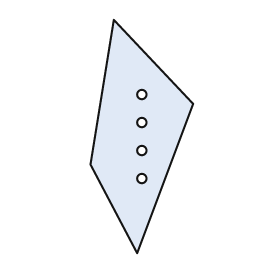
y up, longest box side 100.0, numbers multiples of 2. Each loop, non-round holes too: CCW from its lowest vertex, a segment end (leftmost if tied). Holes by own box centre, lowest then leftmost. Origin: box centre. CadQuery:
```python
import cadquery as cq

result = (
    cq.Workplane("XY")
    .moveTo(-2.0, -50.0)
    .lineTo(22.0, 14.0)
    .lineTo(-12.0, 50.0)
    .lineTo(-22.0, -12.0)
    .close()
    .moveTo(0.0, -18.0)
    .circle(2.0)
    .moveTo(0.0, -6.0)
    .circle(2.0)
    .moveTo(0.0, 6.0)
    .circle(2.0)
    .moveTo(0.0, 18.0)
    .circle(2.0)
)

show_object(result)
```